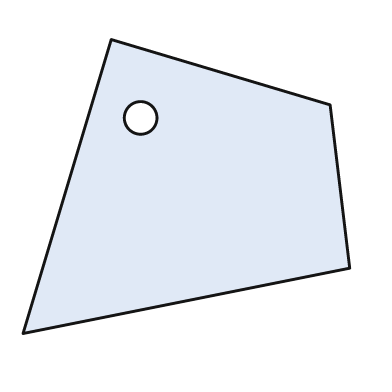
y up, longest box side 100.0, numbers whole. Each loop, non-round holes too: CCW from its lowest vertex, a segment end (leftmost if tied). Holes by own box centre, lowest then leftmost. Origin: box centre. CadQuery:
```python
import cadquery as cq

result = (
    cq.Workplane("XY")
    .moveTo(-50.0, -45.0)
    .lineTo(50.0, -25.0)
    .lineTo(44.0, 25.0)
    .lineTo(-23.0, 45.0)
    .close()
    .moveTo(-14.0, 21.0)
    .circle(5.0)
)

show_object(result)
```